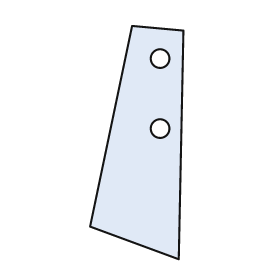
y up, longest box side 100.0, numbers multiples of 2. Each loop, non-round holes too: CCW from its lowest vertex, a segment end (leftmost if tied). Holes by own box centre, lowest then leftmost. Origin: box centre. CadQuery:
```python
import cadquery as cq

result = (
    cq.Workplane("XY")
    .moveTo(18.0, -50.0)
    .lineTo(20.0, 48.0)
    .lineTo(-2.0, 50.0)
    .lineTo(-20.0, -36.0)
    .close()
    .moveTo(10.0, 6.0)
    .circle(4.0)
    .moveTo(10.0, 36.0)
    .circle(4.0)
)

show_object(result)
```